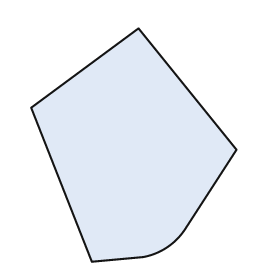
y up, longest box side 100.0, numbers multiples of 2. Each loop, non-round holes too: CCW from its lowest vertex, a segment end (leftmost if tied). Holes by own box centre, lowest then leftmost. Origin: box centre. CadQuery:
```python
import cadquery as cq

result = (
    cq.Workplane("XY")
    .moveTo(-18.0, -50.0)
    .lineTo(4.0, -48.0)
    .threePointArc((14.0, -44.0), (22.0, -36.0))
    .lineTo(44.0, -2.0)
    .lineTo(2.0, 50.0)
    .lineTo(-44.0, 16.0)
    .close()
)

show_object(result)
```